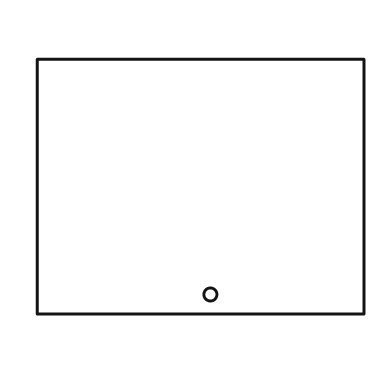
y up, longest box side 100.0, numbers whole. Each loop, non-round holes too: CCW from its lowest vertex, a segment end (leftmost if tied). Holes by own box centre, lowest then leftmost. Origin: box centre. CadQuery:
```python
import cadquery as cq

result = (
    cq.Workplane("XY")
    .moveTo(-50.0, -39.0)
    .lineTo(50.0, -39.0)
    .lineTo(50.0, 39.0)
    .lineTo(-50.0, 39.0)
    .close()
    .moveTo(3.0, -33.0)
    .circle(2.0)
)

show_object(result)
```